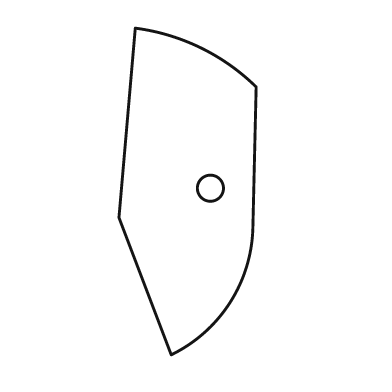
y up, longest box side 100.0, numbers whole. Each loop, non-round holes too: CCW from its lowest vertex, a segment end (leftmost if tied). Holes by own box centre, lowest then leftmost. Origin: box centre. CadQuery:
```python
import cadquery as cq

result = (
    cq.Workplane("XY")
    .moveTo(-5.0, -50.0)
    .threePointArc((13.0, -34.0), (20.0, -11.0))
    .lineTo(21.0, 32.0)
    .threePointArc((4.0, 44.0), (-16.0, 50.0))
    .lineTo(-21.0, -8.0)
    .close()
    .moveTo(7.0, 1.0)
    .circle(4.0)
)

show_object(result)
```